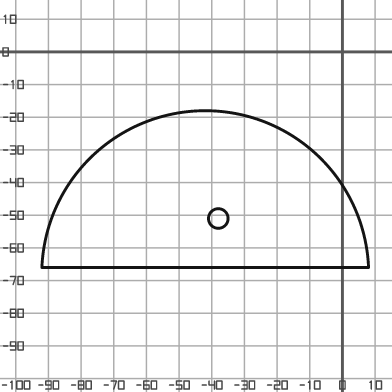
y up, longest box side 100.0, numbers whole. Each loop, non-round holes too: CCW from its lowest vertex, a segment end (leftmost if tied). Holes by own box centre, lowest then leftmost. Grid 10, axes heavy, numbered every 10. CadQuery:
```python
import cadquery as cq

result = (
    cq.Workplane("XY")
    .moveTo(-92.0, -66.0)
    .lineTo(8.0, -66.0)
    .threePointArc((-42.0, -18.0), (-92.0, -66.0))
    .close()
    .moveTo(-38.0, -51.0)
    .circle(3.0)
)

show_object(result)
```